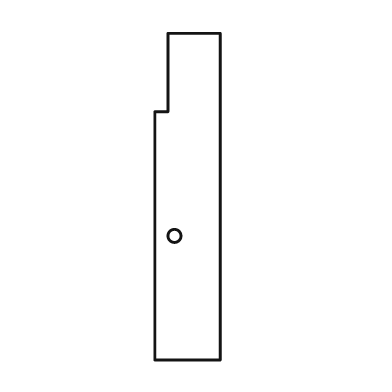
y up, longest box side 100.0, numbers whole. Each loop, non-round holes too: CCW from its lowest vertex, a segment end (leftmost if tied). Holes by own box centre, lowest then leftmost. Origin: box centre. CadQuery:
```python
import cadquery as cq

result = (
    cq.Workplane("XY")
    .moveTo(-10.0, -50.0)
    .lineTo(10.0, -50.0)
    .lineTo(10.0, 50.0)
    .lineTo(-6.0, 50.0)
    .lineTo(-6.0, 26.0)
    .lineTo(-10.0, 26.0)
    .close()
    .moveTo(-4.0, -12.0)
    .circle(2.0)
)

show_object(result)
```